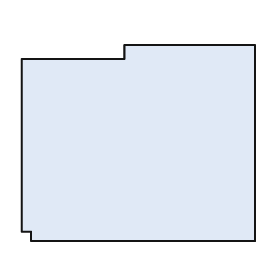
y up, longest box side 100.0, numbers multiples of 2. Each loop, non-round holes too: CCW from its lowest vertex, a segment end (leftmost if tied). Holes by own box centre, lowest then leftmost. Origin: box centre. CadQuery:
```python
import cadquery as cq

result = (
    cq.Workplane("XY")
    .moveTo(-46.0, -42.0)
    .lineTo(50.0, -42.0)
    .lineTo(50.0, 42.0)
    .lineTo(-6.0, 42.0)
    .lineTo(-6.0, 36.0)
    .lineTo(-50.0, 36.0)
    .lineTo(-50.0, -38.0)
    .lineTo(-46.0, -38.0)
    .close()
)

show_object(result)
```